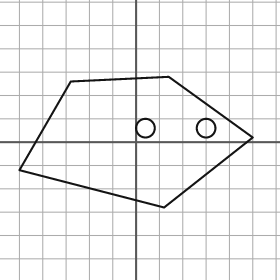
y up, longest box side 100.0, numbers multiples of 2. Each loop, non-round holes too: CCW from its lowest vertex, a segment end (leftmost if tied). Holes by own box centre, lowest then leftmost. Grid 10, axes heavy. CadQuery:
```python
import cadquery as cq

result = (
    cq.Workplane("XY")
    .moveTo(12.0, -28.0)
    .lineTo(50.0, 2.0)
    .lineTo(14.0, 28.0)
    .lineTo(-28.0, 26.0)
    .lineTo(-50.0, -12.0)
    .close()
    .moveTo(4.0, 6.0)
    .circle(4.0)
    .moveTo(30.0, 6.0)
    .circle(4.0)
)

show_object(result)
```